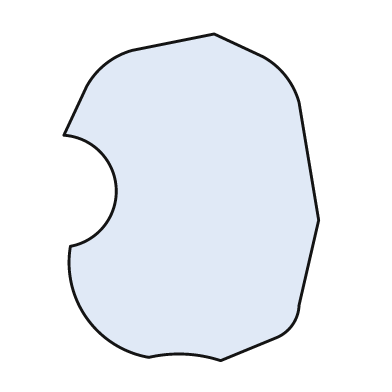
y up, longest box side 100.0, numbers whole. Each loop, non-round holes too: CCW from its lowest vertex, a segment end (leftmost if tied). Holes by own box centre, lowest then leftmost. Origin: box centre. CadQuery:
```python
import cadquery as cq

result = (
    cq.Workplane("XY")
    .moveTo(9.0, -50.0)
    .lineTo(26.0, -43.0)
    .threePointArc((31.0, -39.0), (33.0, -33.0))
    .lineTo(39.0, -7.0)
    .lineTo(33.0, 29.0)
    .threePointArc((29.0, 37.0), (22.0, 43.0))
    .lineTo(7.0, 50.0)
    .lineTo(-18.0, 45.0)
    .threePointArc((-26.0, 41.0), (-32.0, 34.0))
    .lineTo(-39.0, 19.0)
    .threePointArc((-23.0, 3.0), (-37.0, -15.0))
    .threePointArc((-32.0, -37.0), (-13.0, -49.0))
    .threePointArc((-2.0, -48.0), (9.0, -50.0))
    .close()
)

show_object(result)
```